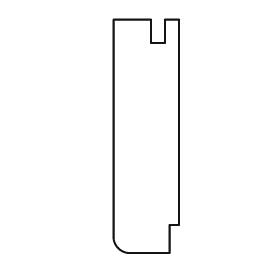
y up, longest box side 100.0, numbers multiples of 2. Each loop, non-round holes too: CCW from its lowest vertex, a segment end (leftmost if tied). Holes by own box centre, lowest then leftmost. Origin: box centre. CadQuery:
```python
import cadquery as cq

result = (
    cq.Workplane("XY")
    .moveTo(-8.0, -50.0)
    .lineTo(10.0, -50.0)
    .lineTo(10.0, -38.0)
    .lineTo(14.0, -38.0)
    .lineTo(14.0, 50.0)
    .lineTo(8.0, 50.0)
    .lineTo(8.0, 40.0)
    .lineTo(2.0, 40.0)
    .lineTo(2.0, 50.0)
    .lineTo(-14.0, 50.0)
    .lineTo(-14.0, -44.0)
    .threePointArc((-12.0, -48.0), (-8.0, -50.0))
    .close()
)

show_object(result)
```